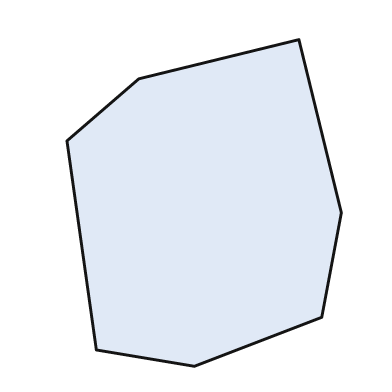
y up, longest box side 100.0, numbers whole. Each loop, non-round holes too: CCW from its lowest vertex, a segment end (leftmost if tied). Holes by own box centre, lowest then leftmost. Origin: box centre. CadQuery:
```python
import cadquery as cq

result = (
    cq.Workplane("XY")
    .moveTo(-3.0, -50.0)
    .lineTo(36.0, -35.0)
    .lineTo(42.0, -3.0)
    .lineTo(29.0, 50.0)
    .lineTo(-20.0, 38.0)
    .lineTo(-42.0, 19.0)
    .lineTo(-33.0, -45.0)
    .close()
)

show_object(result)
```